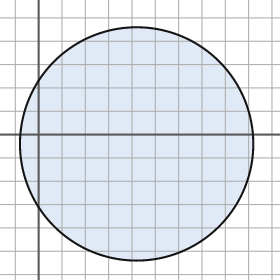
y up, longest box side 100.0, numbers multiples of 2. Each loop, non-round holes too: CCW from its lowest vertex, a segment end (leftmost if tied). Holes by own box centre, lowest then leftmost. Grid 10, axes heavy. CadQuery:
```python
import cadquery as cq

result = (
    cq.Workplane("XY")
    .moveTo(42.0, -4.0)
    .circle(50.0)
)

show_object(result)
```